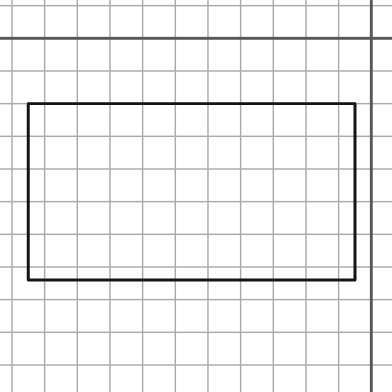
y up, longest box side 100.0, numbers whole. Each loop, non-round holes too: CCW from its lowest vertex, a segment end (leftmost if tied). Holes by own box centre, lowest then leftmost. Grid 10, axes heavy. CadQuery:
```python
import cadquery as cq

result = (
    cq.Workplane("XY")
    .moveTo(-105.0, -74.0)
    .lineTo(-5.0, -74.0)
    .lineTo(-5.0, -20.0)
    .lineTo(-105.0, -20.0)
    .close()
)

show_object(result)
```